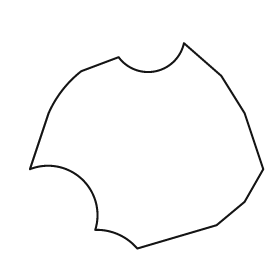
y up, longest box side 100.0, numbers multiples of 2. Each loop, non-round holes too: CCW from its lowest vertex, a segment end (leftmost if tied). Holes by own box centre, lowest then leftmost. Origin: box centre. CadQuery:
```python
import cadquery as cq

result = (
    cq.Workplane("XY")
    .moveTo(-4.0, -44.0)
    .lineTo(30.0, -34.0)
    .lineTo(42.0, -24.0)
    .lineTo(50.0, -10.0)
    .lineTo(42.0, 14.0)
    .lineTo(32.0, 30.0)
    .lineTo(16.0, 44.0)
    .threePointArc((4.0, 32.0), (-12.0, 38.0))
    .lineTo(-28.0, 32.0)
    .threePointArc((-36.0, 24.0), (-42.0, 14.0))
    .lineTo(-50.0, -10.0)
    .threePointArc((-28.0, -14.0), (-22.0, -36.0))
    .threePointArc((-12.0, -38.0), (-4.0, -44.0))
    .close()
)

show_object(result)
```